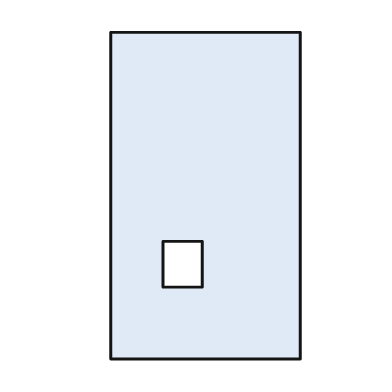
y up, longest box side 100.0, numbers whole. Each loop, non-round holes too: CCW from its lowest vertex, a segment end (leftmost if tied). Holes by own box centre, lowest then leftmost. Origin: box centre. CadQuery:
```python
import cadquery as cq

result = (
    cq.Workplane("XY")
    .moveTo(-29.0, -50.0)
    .lineTo(29.0, -50.0)
    .lineTo(29.0, 50.0)
    .lineTo(-29.0, 50.0)
    .close()
    .moveTo(-13.0, -28.0)
    .lineTo(-1.0, -28.0)
    .lineTo(-1.0, -14.0)
    .lineTo(-13.0, -14.0)
    .close()
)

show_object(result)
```